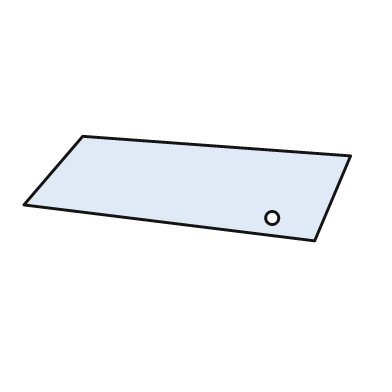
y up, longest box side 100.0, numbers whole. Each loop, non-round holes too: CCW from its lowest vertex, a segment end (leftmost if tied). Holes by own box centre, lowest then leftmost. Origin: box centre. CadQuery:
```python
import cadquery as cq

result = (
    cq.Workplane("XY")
    .moveTo(39.0, -16.0)
    .lineTo(50.0, 10.0)
    .lineTo(-32.0, 16.0)
    .lineTo(-50.0, -5.0)
    .close()
    .moveTo(26.0, -9.0)
    .circle(2.0)
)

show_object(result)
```